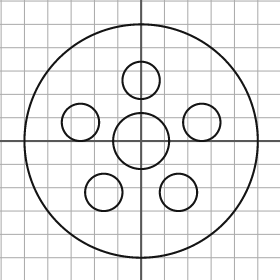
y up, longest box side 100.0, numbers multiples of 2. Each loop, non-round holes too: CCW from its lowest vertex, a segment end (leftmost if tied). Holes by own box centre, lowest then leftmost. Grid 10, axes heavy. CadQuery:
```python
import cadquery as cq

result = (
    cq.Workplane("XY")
    .moveTo(0.0, 0.0)
    .circle(50.0)
    .moveTo(-16.0, -22.0)
    .circle(8.0)
    .moveTo(16.0, -22.0)
    .circle(8.0)
    .moveTo(0.0, 0.0)
    .circle(12.0)
    .moveTo(-26.0, 8.0)
    .circle(8.0)
    .moveTo(26.0, 8.0)
    .circle(8.0)
    .moveTo(0.0, 26.0)
    .circle(8.0)
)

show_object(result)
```